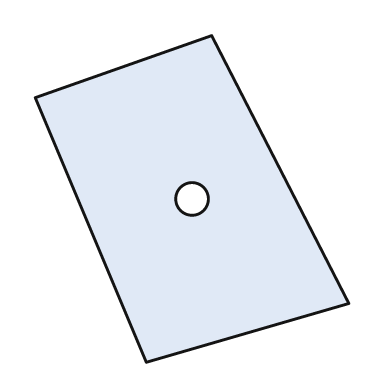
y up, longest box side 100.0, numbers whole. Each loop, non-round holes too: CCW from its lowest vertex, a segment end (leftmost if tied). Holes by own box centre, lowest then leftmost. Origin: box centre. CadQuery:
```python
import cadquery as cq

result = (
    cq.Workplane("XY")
    .moveTo(-14.0, -50.0)
    .lineTo(48.0, -32.0)
    .lineTo(6.0, 50.0)
    .lineTo(-48.0, 31.0)
    .close()
    .moveTo(0.0, 0.0)
    .circle(5.0)
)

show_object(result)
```